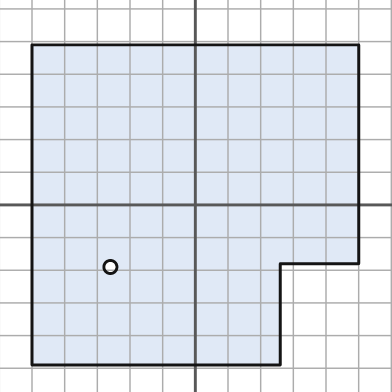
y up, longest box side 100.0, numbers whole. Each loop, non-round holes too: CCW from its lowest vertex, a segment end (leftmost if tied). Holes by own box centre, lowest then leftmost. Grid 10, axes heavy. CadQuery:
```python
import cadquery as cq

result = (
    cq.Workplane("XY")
    .moveTo(-50.0, -49.0)
    .lineTo(26.0, -49.0)
    .lineTo(26.0, -18.0)
    .lineTo(50.0, -18.0)
    .lineTo(50.0, 49.0)
    .lineTo(-50.0, 49.0)
    .close()
    .moveTo(-26.0, -19.0)
    .circle(2.0)
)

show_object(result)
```